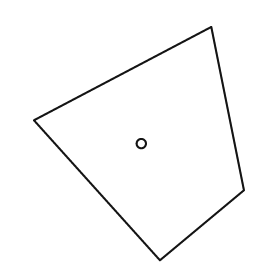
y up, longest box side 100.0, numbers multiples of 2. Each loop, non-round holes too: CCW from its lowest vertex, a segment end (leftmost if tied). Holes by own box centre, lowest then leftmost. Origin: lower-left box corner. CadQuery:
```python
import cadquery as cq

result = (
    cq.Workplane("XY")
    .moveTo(54.0, 0.0)
    .lineTo(90.0, 30.0)
    .lineTo(76.0, 100.0)
    .lineTo(0.0, 60.0)
    .close()
    .moveTo(46.0, 50.0)
    .circle(2.0)
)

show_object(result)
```